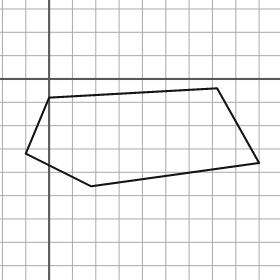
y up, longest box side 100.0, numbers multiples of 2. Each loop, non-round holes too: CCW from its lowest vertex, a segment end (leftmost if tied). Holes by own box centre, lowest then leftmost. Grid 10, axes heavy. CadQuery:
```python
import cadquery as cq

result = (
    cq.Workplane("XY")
    .moveTo(18.0, -46.0)
    .lineTo(90.0, -36.0)
    .lineTo(72.0, -4.0)
    .lineTo(0.0, -8.0)
    .lineTo(-10.0, -32.0)
    .close()
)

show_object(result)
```